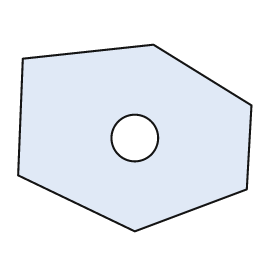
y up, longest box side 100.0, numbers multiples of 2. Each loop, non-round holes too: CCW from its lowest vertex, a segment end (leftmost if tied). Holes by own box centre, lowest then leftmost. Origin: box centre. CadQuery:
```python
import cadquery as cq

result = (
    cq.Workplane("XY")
    .moveTo(0.0, -40.0)
    .lineTo(48.0, -22.0)
    .lineTo(50.0, 14.0)
    .lineTo(8.0, 40.0)
    .lineTo(-48.0, 34.0)
    .lineTo(-50.0, -16.0)
    .close()
    .moveTo(0.0, 0.0)
    .circle(10.0)
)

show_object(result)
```